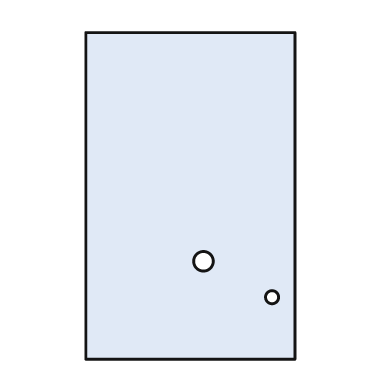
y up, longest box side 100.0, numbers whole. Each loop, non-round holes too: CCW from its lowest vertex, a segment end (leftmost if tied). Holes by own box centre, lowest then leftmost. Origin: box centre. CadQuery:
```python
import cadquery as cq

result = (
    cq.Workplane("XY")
    .moveTo(-32.0, -50.0)
    .lineTo(32.0, -50.0)
    .lineTo(32.0, 50.0)
    .lineTo(-32.0, 50.0)
    .close()
    .moveTo(25.0, -31.0)
    .circle(2.0)
    .moveTo(4.0, -20.0)
    .circle(3.0)
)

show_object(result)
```